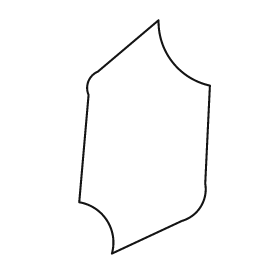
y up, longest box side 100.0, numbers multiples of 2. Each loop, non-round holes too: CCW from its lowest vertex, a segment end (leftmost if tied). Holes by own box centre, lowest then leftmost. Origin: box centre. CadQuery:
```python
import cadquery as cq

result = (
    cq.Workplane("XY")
    .moveTo(-14.0, -50.0)
    .lineTo(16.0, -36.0)
    .threePointArc((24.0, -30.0), (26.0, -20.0))
    .lineTo(28.0, 22.0)
    .threePointArc((12.0, 32.0), (6.0, 50.0))
    .lineTo(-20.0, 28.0)
    .threePointArc((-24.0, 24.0), (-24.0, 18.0))
    .lineTo(-28.0, -28.0)
    .threePointArc((-16.0, -36.0), (-14.0, -50.0))
    .close()
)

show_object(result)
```